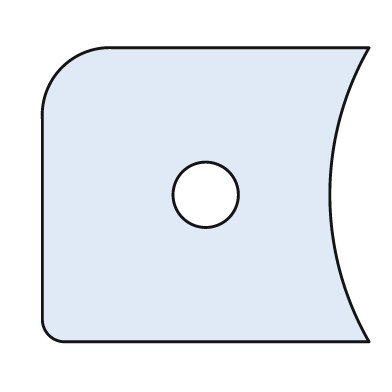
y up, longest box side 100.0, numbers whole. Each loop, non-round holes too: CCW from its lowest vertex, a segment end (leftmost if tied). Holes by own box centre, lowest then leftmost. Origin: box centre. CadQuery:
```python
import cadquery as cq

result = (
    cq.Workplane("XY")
    .moveTo(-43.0, -45.0)
    .lineTo(50.0, -45.0)
    .threePointArc((38.0, 0.0), (50.0, 45.0))
    .lineTo(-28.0, 45.0)
    .threePointArc((-44.0, 39.0), (-50.0, 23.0))
    .lineTo(-50.0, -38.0)
    .threePointArc((-48.0, -43.0), (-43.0, -45.0))
    .close()
    .moveTo(0.0, 0.0)
    .circle(10.0)
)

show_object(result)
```